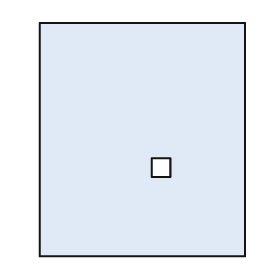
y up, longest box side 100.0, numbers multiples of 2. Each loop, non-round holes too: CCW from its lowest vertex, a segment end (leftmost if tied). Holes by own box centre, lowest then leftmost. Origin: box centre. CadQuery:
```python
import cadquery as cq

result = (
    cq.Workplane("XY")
    .moveTo(-44.0, -50.0)
    .lineTo(44.0, -50.0)
    .lineTo(44.0, 50.0)
    .lineTo(-44.0, 50.0)
    .close()
    .moveTo(4.0, -16.0)
    .lineTo(12.0, -16.0)
    .lineTo(12.0, -8.0)
    .lineTo(4.0, -8.0)
    .close()
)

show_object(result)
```